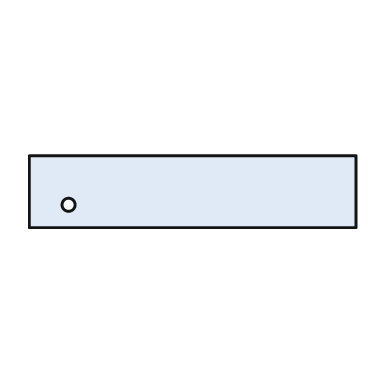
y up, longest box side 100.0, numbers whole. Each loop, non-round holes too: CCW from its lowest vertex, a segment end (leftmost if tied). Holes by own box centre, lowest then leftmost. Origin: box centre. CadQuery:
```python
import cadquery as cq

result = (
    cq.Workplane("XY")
    .moveTo(-50.0, -11.0)
    .lineTo(50.0, -11.0)
    .lineTo(50.0, 11.0)
    .lineTo(-50.0, 11.0)
    .close()
    .moveTo(-38.0, -4.0)
    .circle(2.0)
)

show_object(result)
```